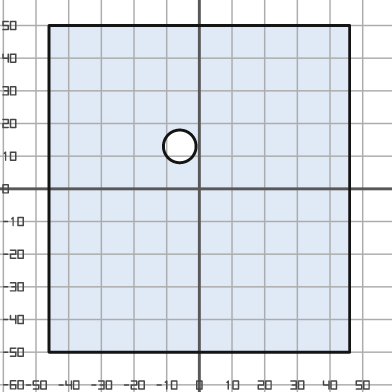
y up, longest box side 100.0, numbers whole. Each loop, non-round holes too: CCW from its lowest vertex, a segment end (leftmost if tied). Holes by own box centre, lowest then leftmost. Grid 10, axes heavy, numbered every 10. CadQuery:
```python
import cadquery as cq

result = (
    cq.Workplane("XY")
    .moveTo(-46.0, -50.0)
    .lineTo(46.0, -50.0)
    .lineTo(46.0, 50.0)
    .lineTo(-46.0, 50.0)
    .close()
    .moveTo(-6.0, 13.0)
    .circle(5.0)
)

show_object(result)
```